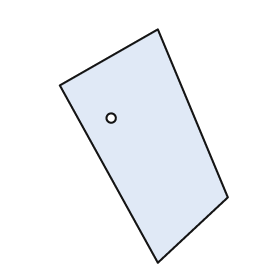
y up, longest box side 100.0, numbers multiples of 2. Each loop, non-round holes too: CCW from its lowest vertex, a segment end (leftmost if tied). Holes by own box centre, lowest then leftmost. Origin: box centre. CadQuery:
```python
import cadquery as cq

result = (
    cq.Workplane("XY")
    .moveTo(6.0, -50.0)
    .lineTo(36.0, -22.0)
    .lineTo(6.0, 50.0)
    .lineTo(-36.0, 26.0)
    .close()
    .moveTo(-14.0, 12.0)
    .circle(2.0)
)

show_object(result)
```